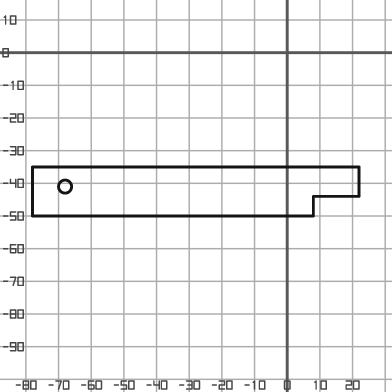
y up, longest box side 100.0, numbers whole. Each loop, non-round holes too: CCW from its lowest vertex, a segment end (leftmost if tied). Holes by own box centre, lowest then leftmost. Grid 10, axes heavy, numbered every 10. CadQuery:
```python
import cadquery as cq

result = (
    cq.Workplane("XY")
    .moveTo(-78.0, -50.0)
    .lineTo(8.0, -50.0)
    .lineTo(8.0, -44.0)
    .lineTo(22.0, -44.0)
    .lineTo(22.0, -35.0)
    .lineTo(-78.0, -35.0)
    .close()
    .moveTo(-68.0, -41.0)
    .circle(2.0)
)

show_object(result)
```